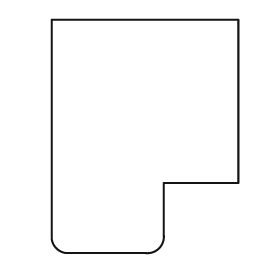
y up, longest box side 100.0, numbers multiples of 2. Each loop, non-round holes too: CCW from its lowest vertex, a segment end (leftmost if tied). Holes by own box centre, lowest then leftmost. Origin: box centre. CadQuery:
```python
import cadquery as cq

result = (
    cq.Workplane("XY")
    .moveTo(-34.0, -50.0)
    .lineTo(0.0, -50.0)
    .threePointArc((6.0, -48.0), (8.0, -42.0))
    .lineTo(8.0, -20.0)
    .lineTo(40.0, -20.0)
    .lineTo(40.0, 50.0)
    .lineTo(-40.0, 50.0)
    .lineTo(-40.0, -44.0)
    .threePointArc((-38.0, -48.0), (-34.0, -50.0))
    .close()
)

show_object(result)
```